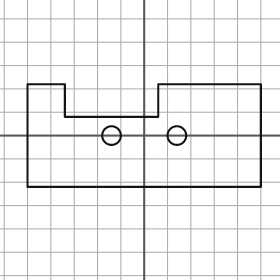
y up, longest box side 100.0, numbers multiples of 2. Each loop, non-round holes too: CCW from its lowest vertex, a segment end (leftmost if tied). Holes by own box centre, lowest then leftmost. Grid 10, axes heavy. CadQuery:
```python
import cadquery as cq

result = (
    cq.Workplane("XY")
    .moveTo(-50.0, -22.0)
    .lineTo(50.0, -22.0)
    .lineTo(50.0, 22.0)
    .lineTo(6.0, 22.0)
    .lineTo(6.0, 8.0)
    .lineTo(-34.0, 8.0)
    .lineTo(-34.0, 22.0)
    .lineTo(-50.0, 22.0)
    .close()
    .moveTo(-14.0, 0.0)
    .circle(4.0)
    .moveTo(14.0, 0.0)
    .circle(4.0)
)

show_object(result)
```